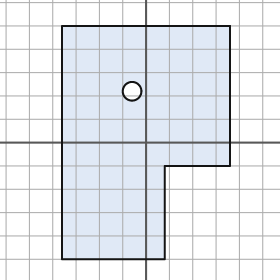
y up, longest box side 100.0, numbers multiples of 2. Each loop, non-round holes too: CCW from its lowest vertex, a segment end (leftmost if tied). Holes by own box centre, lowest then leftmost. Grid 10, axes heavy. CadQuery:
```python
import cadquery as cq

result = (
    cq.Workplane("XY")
    .moveTo(-36.0, -50.0)
    .lineTo(8.0, -50.0)
    .lineTo(8.0, -10.0)
    .lineTo(36.0, -10.0)
    .lineTo(36.0, 50.0)
    .lineTo(-36.0, 50.0)
    .close()
    .moveTo(-6.0, 22.0)
    .circle(4.0)
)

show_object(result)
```